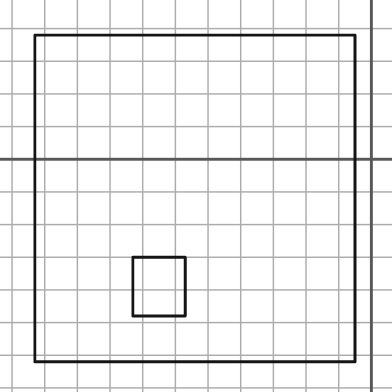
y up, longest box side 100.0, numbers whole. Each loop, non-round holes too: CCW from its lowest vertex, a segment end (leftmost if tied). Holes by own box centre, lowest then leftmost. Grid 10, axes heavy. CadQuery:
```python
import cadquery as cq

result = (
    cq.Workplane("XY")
    .moveTo(-103.0, -62.0)
    .lineTo(-5.0, -62.0)
    .lineTo(-5.0, 38.0)
    .lineTo(-103.0, 38.0)
    .close()
    .moveTo(-73.0, -48.0)
    .lineTo(-57.0, -48.0)
    .lineTo(-57.0, -30.0)
    .lineTo(-73.0, -30.0)
    .close()
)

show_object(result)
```